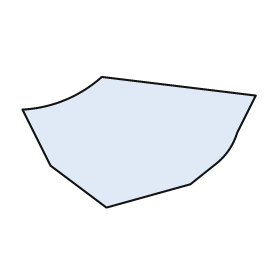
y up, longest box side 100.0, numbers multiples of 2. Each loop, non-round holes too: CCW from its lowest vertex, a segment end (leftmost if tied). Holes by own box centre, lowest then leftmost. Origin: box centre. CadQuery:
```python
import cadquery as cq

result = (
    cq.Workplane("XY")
    .moveTo(-14.0, -28.0)
    .lineTo(22.0, -18.0)
    .lineTo(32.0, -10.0)
    .threePointArc((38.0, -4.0), (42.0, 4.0))
    .lineTo(50.0, 20.0)
    .lineTo(-16.0, 28.0)
    .threePointArc((-32.0, 18.0), (-50.0, 14.0))
    .lineTo(-38.0, -10.0)
    .close()
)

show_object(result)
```